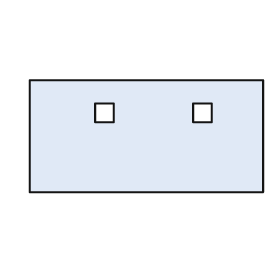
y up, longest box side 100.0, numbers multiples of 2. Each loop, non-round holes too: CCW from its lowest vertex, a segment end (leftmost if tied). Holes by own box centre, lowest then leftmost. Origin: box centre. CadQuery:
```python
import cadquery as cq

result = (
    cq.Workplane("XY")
    .moveTo(-50.0, -24.0)
    .lineTo(50.0, -24.0)
    .lineTo(50.0, 24.0)
    .lineTo(-50.0, 24.0)
    .close()
    .moveTo(-22.0, 6.0)
    .lineTo(-14.0, 6.0)
    .lineTo(-14.0, 14.0)
    .lineTo(-22.0, 14.0)
    .close()
    .moveTo(20.0, 6.0)
    .lineTo(28.0, 6.0)
    .lineTo(28.0, 14.0)
    .lineTo(20.0, 14.0)
    .close()
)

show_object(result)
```